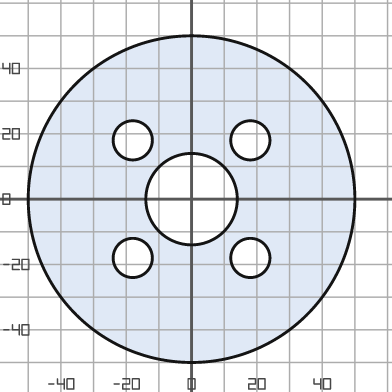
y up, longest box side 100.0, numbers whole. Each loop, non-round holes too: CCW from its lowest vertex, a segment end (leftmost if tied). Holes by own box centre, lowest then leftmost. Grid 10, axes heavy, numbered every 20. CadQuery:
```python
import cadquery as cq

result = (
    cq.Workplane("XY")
    .moveTo(0.0, 0.0)
    .circle(50.0)
    .moveTo(-18.0, -18.0)
    .circle(6.0)
    .moveTo(18.0, -18.0)
    .circle(6.0)
    .moveTo(0.0, 0.0)
    .circle(14.0)
    .moveTo(-18.0, 18.0)
    .circle(6.0)
    .moveTo(18.0, 18.0)
    .circle(6.0)
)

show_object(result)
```